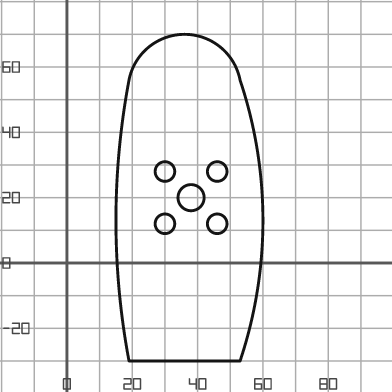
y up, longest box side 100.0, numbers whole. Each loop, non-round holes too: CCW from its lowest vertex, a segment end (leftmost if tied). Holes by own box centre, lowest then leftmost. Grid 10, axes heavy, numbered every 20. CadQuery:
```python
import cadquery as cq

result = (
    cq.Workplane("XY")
    .moveTo(19.0, -30.0)
    .lineTo(53.0, -30.0)
    .threePointArc((60.0, 13.0), (53.0, 56.0))
    .threePointArc((36.0, 70.0), (19.0, 56.0))
    .threePointArc((15.0, 13.0), (19.0, -30.0))
    .close()
    .moveTo(30.0, 12.0)
    .circle(3.0)
    .moveTo(46.0, 12.0)
    .circle(3.0)
    .moveTo(38.0, 20.0)
    .circle(4.0)
    .moveTo(30.0, 28.0)
    .circle(3.0)
    .moveTo(46.0, 28.0)
    .circle(3.0)
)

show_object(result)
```